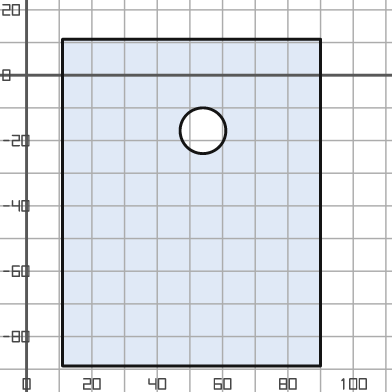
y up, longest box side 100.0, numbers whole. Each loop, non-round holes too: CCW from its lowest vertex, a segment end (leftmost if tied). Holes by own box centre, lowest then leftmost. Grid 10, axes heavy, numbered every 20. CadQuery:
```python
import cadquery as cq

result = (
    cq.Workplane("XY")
    .moveTo(11.0, -89.0)
    .lineTo(90.0, -89.0)
    .lineTo(90.0, 11.0)
    .lineTo(11.0, 11.0)
    .close()
    .moveTo(54.0, -17.0)
    .circle(7.0)
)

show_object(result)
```